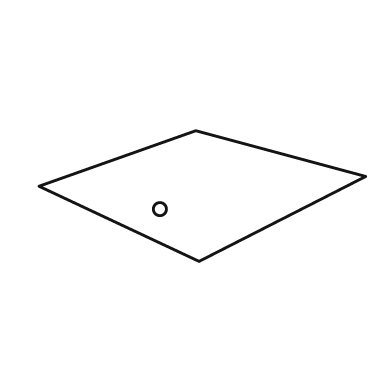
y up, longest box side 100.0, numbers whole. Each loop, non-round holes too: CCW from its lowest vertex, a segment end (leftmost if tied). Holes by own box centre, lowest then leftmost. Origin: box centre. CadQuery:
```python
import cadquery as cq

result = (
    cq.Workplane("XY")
    .moveTo(-1.0, -20.0)
    .lineTo(50.0, 6.0)
    .lineTo(-2.0, 20.0)
    .lineTo(-50.0, 3.0)
    .close()
    .moveTo(-13.0, -4.0)
    .circle(2.0)
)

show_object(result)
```